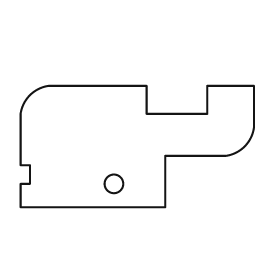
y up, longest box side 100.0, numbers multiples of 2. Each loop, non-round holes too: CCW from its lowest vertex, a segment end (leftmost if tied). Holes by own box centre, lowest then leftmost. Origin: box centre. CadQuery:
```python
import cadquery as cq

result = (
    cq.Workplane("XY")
    .moveTo(-50.0, -26.0)
    .lineTo(12.0, -26.0)
    .lineTo(12.0, -4.0)
    .lineTo(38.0, -4.0)
    .threePointArc((46.0, 0.0), (50.0, 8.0))
    .lineTo(50.0, 26.0)
    .lineTo(30.0, 26.0)
    .lineTo(30.0, 14.0)
    .lineTo(4.0, 14.0)
    .lineTo(4.0, 26.0)
    .lineTo(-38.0, 26.0)
    .threePointArc((-46.0, 22.0), (-50.0, 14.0))
    .lineTo(-50.0, -8.0)
    .lineTo(-46.0, -8.0)
    .lineTo(-46.0, -16.0)
    .lineTo(-50.0, -16.0)
    .close()
    .moveTo(-10.0, -16.0)
    .circle(4.0)
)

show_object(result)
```